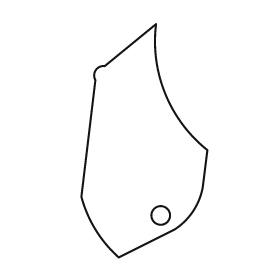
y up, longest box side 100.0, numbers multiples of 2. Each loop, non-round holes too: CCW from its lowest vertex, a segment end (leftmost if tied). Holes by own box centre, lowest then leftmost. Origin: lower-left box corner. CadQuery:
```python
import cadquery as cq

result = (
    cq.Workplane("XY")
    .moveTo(16.0, 0.0)
    .lineTo(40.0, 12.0)
    .threePointArc((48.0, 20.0), (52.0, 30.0))
    .lineTo(54.0, 46.0)
    .threePointArc((36.0, 70.0), (32.0, 100.0))
    .lineTo(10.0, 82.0)
    .threePointArc((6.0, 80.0), (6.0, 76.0))
    .lineTo(0.0, 26.0)
    .threePointArc((6.0, 12.0), (16.0, 0.0))
    .close()
    .moveTo(34.0, 18.0)
    .circle(4.0)
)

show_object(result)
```